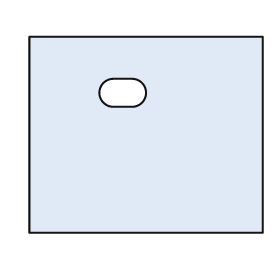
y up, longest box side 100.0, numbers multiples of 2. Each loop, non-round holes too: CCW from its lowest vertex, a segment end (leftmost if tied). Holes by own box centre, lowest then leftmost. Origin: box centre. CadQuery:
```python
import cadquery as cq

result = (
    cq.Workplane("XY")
    .moveTo(-50.0, -42.0)
    .lineTo(50.0, -42.0)
    .lineTo(50.0, 42.0)
    .lineTo(-50.0, 42.0)
    .close()
    .moveTo(-14.0, 12.0)
    .lineTo(-6.0, 12.0)
    .threePointArc((0.0, 18.0), (-6.0, 24.0))
    .lineTo(-14.0, 24.0)
    .threePointArc((-20.0, 18.0), (-14.0, 12.0))
    .close()
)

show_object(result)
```